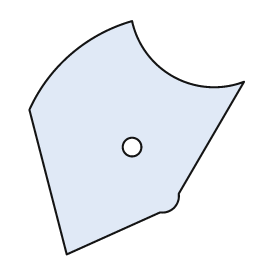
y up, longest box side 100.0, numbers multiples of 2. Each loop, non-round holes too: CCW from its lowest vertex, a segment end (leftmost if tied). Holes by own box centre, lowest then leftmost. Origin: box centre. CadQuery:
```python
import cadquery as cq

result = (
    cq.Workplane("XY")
    .moveTo(-30.0, -50.0)
    .lineTo(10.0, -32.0)
    .threePointArc((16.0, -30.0), (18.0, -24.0))
    .lineTo(46.0, 24.0)
    .threePointArc((16.0, 26.0), (-2.0, 50.0))
    .threePointArc((-28.0, 36.0), (-46.0, 12.0))
    .close()
    .moveTo(-2.0, -4.0)
    .circle(4.0)
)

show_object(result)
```